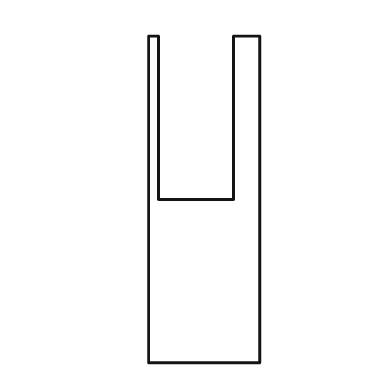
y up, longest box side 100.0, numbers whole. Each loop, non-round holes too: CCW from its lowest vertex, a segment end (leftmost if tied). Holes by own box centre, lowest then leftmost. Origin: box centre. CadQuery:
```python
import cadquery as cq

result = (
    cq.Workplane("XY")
    .moveTo(-17.0, -50.0)
    .lineTo(17.0, -50.0)
    .lineTo(17.0, 50.0)
    .lineTo(9.0, 50.0)
    .lineTo(9.0, 0.0)
    .lineTo(-14.0, 0.0)
    .lineTo(-14.0, 50.0)
    .lineTo(-17.0, 50.0)
    .close()
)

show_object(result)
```